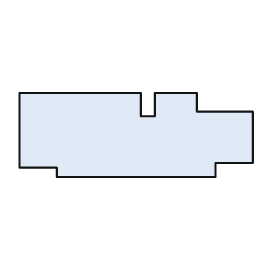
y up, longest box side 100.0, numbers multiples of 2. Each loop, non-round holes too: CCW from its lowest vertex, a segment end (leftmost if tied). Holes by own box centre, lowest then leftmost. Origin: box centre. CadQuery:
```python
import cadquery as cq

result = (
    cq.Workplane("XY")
    .moveTo(-34.0, -18.0)
    .lineTo(34.0, -18.0)
    .lineTo(34.0, -12.0)
    .lineTo(50.0, -12.0)
    .lineTo(50.0, 10.0)
    .lineTo(26.0, 10.0)
    .lineTo(26.0, 18.0)
    .lineTo(8.0, 18.0)
    .lineTo(8.0, 8.0)
    .lineTo(2.0, 8.0)
    .lineTo(2.0, 18.0)
    .lineTo(-50.0, 18.0)
    .lineTo(-50.0, -14.0)
    .lineTo(-34.0, -14.0)
    .close()
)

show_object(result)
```